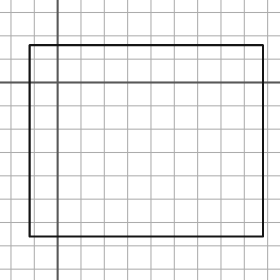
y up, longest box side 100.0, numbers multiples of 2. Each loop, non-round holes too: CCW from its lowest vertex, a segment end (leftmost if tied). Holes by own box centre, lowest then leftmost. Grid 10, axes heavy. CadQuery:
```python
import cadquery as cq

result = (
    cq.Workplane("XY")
    .moveTo(-12.0, -66.0)
    .lineTo(88.0, -66.0)
    .lineTo(88.0, 16.0)
    .lineTo(-12.0, 16.0)
    .close()
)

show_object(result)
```